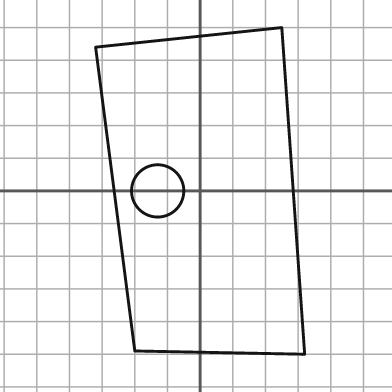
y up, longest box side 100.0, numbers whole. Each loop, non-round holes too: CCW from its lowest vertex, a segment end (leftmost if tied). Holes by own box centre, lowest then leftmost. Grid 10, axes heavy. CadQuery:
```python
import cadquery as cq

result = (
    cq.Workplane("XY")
    .moveTo(32.0, -50.0)
    .lineTo(25.0, 50.0)
    .lineTo(-32.0, 44.0)
    .lineTo(-20.0, -49.0)
    .close()
    .moveTo(-13.0, 0.0)
    .circle(8.0)
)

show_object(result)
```